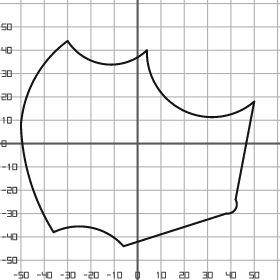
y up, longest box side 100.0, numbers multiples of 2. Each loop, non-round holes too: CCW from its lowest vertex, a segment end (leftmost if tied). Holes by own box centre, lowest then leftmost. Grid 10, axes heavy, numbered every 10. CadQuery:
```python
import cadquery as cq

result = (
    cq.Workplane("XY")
    .moveTo(-6.0, -44.0)
    .lineTo(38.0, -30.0)
    .threePointArc((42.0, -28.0), (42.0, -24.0))
    .lineTo(50.0, 18.0)
    .threePointArc((20.0, 14.0), (4.0, 40.0))
    .threePointArc((-14.0, 34.0), (-30.0, 44.0))
    .threePointArc((-44.0, 28.0), (-50.0, 8.0))
    .threePointArc((-46.0, -16.0), (-36.0, -38.0))
    .threePointArc((-20.0, -36.0), (-6.0, -44.0))
    .close()
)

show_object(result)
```